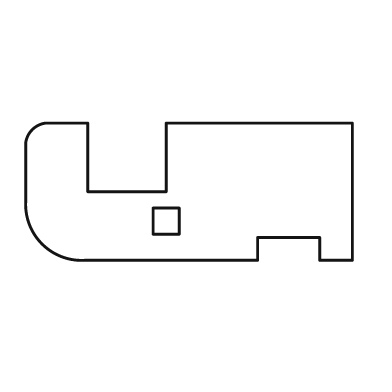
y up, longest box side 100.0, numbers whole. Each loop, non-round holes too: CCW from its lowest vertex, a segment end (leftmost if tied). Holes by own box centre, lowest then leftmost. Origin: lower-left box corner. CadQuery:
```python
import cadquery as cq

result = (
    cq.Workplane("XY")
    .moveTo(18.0, 0.0)
    .lineTo(71.0, 0.0)
    .lineTo(71.0, 7.0)
    .lineTo(90.0, 7.0)
    .lineTo(90.0, 0.0)
    .lineTo(100.0, 0.0)
    .lineTo(100.0, 42.0)
    .lineTo(43.0, 42.0)
    .lineTo(43.0, 21.0)
    .lineTo(19.0, 21.0)
    .lineTo(19.0, 42.0)
    .lineTo(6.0, 42.0)
    .threePointArc((2.0, 40.0), (0.0, 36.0))
    .lineTo(0.0, 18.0)
    .threePointArc((5.0, 5.0), (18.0, 0.0))
    .close()
    .moveTo(39.0, 8.0)
    .lineTo(47.0, 8.0)
    .lineTo(47.0, 16.0)
    .lineTo(39.0, 16.0)
    .close()
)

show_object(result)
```